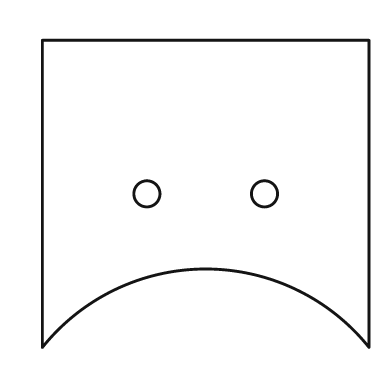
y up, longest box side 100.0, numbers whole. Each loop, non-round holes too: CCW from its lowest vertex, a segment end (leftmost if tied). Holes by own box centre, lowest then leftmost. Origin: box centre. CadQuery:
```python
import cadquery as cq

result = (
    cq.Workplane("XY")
    .moveTo(-50.0, -47.0)
    .threePointArc((0.0, -23.0), (50.0, -47.0))
    .lineTo(50.0, 47.0)
    .lineTo(-50.0, 47.0)
    .close()
    .moveTo(-18.0, 0.0)
    .circle(4.0)
    .moveTo(18.0, 0.0)
    .circle(4.0)
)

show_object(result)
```